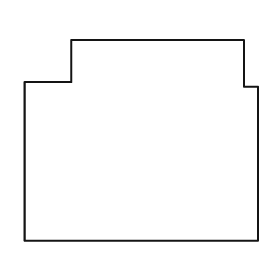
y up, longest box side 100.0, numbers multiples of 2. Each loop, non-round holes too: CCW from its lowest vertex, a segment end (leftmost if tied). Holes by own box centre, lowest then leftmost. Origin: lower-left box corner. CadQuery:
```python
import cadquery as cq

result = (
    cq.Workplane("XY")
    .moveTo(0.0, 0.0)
    .lineTo(100.0, 0.0)
    .lineTo(100.0, 66.0)
    .lineTo(94.0, 66.0)
    .lineTo(94.0, 86.0)
    .lineTo(20.0, 86.0)
    .lineTo(20.0, 68.0)
    .lineTo(0.0, 68.0)
    .close()
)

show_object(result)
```